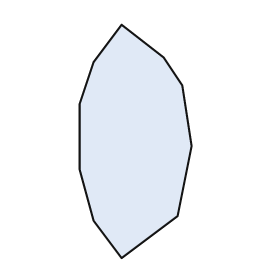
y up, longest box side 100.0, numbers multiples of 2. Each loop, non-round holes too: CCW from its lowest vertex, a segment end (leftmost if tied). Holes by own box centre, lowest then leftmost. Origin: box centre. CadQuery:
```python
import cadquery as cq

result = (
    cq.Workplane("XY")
    .moveTo(-6.0, -50.0)
    .lineTo(18.0, -32.0)
    .lineTo(24.0, -2.0)
    .lineTo(20.0, 24.0)
    .lineTo(12.0, 36.0)
    .lineTo(-6.0, 50.0)
    .lineTo(-18.0, 34.0)
    .lineTo(-24.0, 16.0)
    .lineTo(-24.0, -12.0)
    .lineTo(-18.0, -34.0)
    .close()
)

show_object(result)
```